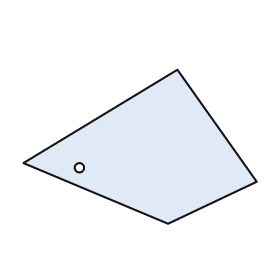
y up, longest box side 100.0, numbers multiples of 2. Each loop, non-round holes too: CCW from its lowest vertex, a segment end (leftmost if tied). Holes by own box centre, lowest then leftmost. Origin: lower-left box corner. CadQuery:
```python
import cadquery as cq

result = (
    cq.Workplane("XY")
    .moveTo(62.0, 0.0)
    .lineTo(100.0, 18.0)
    .lineTo(66.0, 66.0)
    .lineTo(0.0, 26.0)
    .close()
    .moveTo(24.0, 24.0)
    .circle(2.0)
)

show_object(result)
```